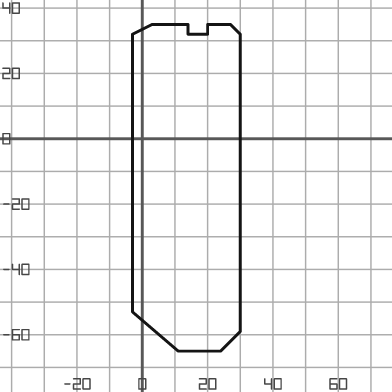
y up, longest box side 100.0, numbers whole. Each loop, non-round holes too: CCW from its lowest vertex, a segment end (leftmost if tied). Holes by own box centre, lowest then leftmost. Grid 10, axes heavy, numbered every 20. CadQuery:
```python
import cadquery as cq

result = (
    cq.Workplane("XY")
    .moveTo(11.0, -65.0)
    .lineTo(24.0, -65.0)
    .lineTo(30.0, -59.0)
    .lineTo(30.0, 32.0)
    .lineTo(27.0, 35.0)
    .lineTo(20.0, 35.0)
    .lineTo(20.0, 32.0)
    .lineTo(14.0, 32.0)
    .lineTo(14.0, 35.0)
    .lineTo(3.0, 35.0)
    .lineTo(-3.0, 32.0)
    .lineTo(-3.0, -53.0)
    .close()
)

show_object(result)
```